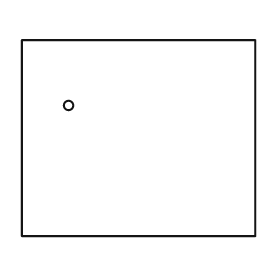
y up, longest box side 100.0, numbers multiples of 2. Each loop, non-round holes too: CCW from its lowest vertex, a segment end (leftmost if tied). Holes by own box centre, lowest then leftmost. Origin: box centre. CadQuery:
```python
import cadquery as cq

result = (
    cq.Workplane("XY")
    .moveTo(-50.0, -42.0)
    .lineTo(50.0, -42.0)
    .lineTo(50.0, 42.0)
    .lineTo(-50.0, 42.0)
    .close()
    .moveTo(-30.0, 14.0)
    .circle(2.0)
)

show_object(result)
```